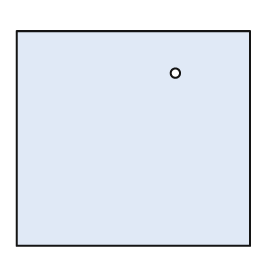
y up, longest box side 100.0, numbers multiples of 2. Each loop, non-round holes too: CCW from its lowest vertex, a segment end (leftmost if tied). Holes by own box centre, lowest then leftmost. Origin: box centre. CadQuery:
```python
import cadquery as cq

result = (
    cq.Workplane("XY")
    .moveTo(-50.0, -46.0)
    .lineTo(50.0, -46.0)
    .lineTo(50.0, 46.0)
    .lineTo(-50.0, 46.0)
    .close()
    .moveTo(18.0, 28.0)
    .circle(2.0)
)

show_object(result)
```